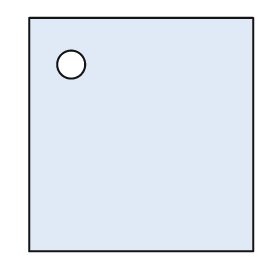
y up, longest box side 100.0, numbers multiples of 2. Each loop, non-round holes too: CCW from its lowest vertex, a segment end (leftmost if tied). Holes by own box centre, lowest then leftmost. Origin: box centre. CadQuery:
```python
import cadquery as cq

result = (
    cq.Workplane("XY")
    .moveTo(-48.0, -50.0)
    .lineTo(48.0, -50.0)
    .lineTo(48.0, 50.0)
    .lineTo(-48.0, 50.0)
    .close()
    .moveTo(-30.0, 30.0)
    .circle(6.0)
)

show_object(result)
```